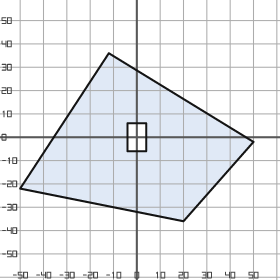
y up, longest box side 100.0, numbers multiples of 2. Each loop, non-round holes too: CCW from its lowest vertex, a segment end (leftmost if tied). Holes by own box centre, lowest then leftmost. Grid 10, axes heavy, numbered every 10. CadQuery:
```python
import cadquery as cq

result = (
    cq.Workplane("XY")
    .moveTo(20.0, -36.0)
    .lineTo(50.0, -2.0)
    .lineTo(-12.0, 36.0)
    .lineTo(-50.0, -22.0)
    .close()
    .moveTo(-4.0, -6.0)
    .lineTo(4.0, -6.0)
    .lineTo(4.0, 6.0)
    .lineTo(-4.0, 6.0)
    .close()
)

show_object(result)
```